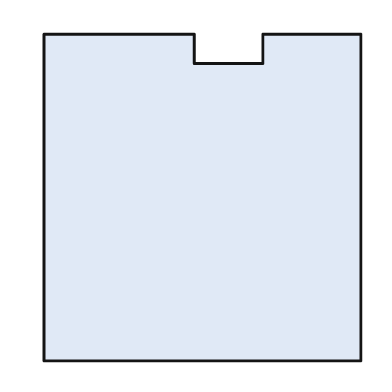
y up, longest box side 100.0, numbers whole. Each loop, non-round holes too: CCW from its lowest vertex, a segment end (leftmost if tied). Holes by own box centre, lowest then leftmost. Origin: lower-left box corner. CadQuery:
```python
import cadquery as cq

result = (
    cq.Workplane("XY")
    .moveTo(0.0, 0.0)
    .lineTo(97.0, 0.0)
    .lineTo(97.0, 100.0)
    .lineTo(67.0, 100.0)
    .lineTo(67.0, 91.0)
    .lineTo(46.0, 91.0)
    .lineTo(46.0, 100.0)
    .lineTo(0.0, 100.0)
    .close()
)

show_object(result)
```